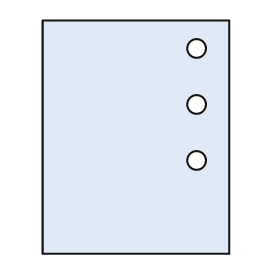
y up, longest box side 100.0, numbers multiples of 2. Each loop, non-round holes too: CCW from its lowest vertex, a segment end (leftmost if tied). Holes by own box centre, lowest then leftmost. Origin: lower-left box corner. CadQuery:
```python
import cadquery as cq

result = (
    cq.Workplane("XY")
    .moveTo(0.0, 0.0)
    .lineTo(80.0, 0.0)
    .lineTo(80.0, 100.0)
    .lineTo(0.0, 100.0)
    .close()
    .moveTo(66.0, 40.0)
    .circle(4.0)
    .moveTo(66.0, 64.0)
    .circle(4.0)
    .moveTo(66.0, 88.0)
    .circle(4.0)
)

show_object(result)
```